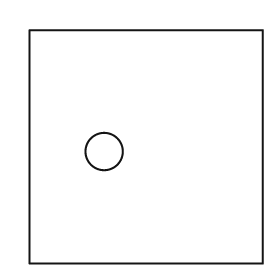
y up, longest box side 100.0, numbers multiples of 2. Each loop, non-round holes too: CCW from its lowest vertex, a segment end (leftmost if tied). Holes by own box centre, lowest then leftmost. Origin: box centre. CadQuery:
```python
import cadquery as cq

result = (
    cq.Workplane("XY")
    .moveTo(-50.0, -50.0)
    .lineTo(50.0, -50.0)
    .lineTo(50.0, 50.0)
    .lineTo(-50.0, 50.0)
    .close()
    .moveTo(-18.0, -2.0)
    .circle(8.0)
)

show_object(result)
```